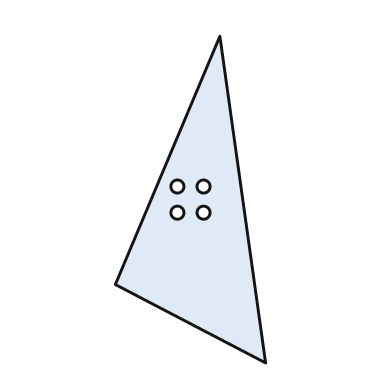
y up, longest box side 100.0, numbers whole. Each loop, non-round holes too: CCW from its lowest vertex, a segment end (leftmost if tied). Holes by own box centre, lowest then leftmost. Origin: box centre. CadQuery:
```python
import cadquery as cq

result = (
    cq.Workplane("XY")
    .moveTo(23.0, -50.0)
    .lineTo(9.0, 50.0)
    .lineTo(-23.0, -26.0)
    .close()
    .moveTo(-4.0, -4.0)
    .circle(2.0)
    .moveTo(4.0, -4.0)
    .circle(2.0)
    .moveTo(-4.0, 4.0)
    .circle(2.0)
    .moveTo(4.0, 4.0)
    .circle(2.0)
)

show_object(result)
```